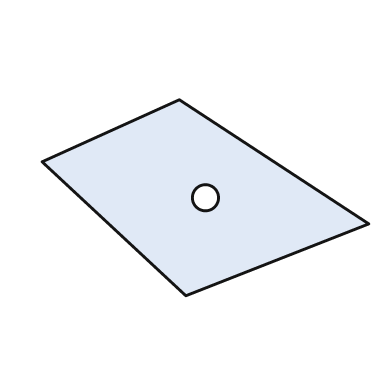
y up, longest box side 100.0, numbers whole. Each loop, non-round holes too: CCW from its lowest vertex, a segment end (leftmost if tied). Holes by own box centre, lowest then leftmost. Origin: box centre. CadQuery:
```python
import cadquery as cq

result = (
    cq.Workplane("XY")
    .moveTo(-6.0, -30.0)
    .lineTo(50.0, -8.0)
    .lineTo(-8.0, 30.0)
    .lineTo(-50.0, 11.0)
    .close()
    .moveTo(0.0, 0.0)
    .circle(4.0)
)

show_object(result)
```